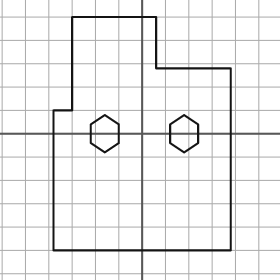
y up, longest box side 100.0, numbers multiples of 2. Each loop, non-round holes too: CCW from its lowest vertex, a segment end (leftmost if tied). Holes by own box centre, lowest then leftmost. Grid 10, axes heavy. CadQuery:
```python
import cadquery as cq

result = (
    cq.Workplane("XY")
    .moveTo(-38.0, -50.0)
    .lineTo(38.0, -50.0)
    .lineTo(38.0, 28.0)
    .lineTo(6.0, 28.0)
    .lineTo(6.0, 50.0)
    .lineTo(-30.0, 50.0)
    .lineTo(-30.0, 10.0)
    .lineTo(-38.0, 10.0)
    .close()
    .moveTo(-16.0, -8.0)
    .lineTo(-10.0, -4.0)
    .lineTo(-10.0, 4.0)
    .lineTo(-16.0, 8.0)
    .lineTo(-22.0, 4.0)
    .lineTo(-22.0, -4.0)
    .close()
    .moveTo(18.0, -8.0)
    .lineTo(24.0, -4.0)
    .lineTo(24.0, 4.0)
    .lineTo(18.0, 8.0)
    .lineTo(12.0, 4.0)
    .lineTo(12.0, -4.0)
    .close()
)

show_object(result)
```